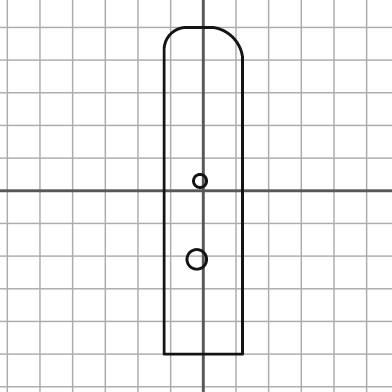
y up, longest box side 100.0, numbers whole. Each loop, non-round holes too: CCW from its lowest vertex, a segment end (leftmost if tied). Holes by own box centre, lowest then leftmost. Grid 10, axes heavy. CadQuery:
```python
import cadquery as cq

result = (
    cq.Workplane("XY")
    .moveTo(-12.0, -50.0)
    .lineTo(12.0, -50.0)
    .lineTo(12.0, 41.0)
    .threePointArc((9.0, 47.0), (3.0, 50.0))
    .lineTo(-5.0, 50.0)
    .threePointArc((-10.0, 48.0), (-12.0, 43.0))
    .close()
    .moveTo(-2.0, -21.0)
    .circle(3.0)
    .moveTo(-1.0, 3.0)
    .circle(2.0)
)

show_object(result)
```